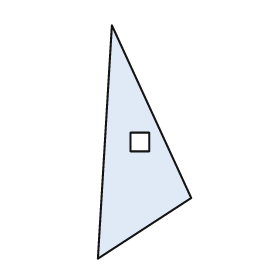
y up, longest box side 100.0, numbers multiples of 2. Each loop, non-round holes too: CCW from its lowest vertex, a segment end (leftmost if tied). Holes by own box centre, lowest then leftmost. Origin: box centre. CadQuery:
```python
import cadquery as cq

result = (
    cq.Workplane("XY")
    .moveTo(-20.0, -50.0)
    .lineTo(20.0, -24.0)
    .lineTo(-14.0, 50.0)
    .close()
    .moveTo(-6.0, -4.0)
    .lineTo(2.0, -4.0)
    .lineTo(2.0, 4.0)
    .lineTo(-6.0, 4.0)
    .close()
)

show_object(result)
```